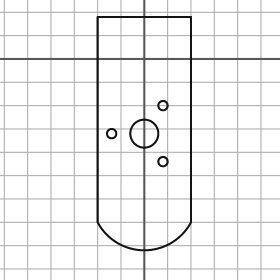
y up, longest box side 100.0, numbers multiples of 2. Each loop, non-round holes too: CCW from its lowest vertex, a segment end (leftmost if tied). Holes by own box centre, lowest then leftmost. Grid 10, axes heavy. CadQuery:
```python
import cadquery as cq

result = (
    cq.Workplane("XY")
    .moveTo(-20.0, -70.0)
    .threePointArc((0.0, -82.0), (20.0, -70.0))
    .lineTo(20.0, 18.0)
    .lineTo(-20.0, 18.0)
    .close()
    .moveTo(8.0, -44.0)
    .circle(2.0)
    .moveTo(-14.0, -32.0)
    .circle(2.0)
    .moveTo(0.0, -32.0)
    .circle(6.0)
    .moveTo(8.0, -20.0)
    .circle(2.0)
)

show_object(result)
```